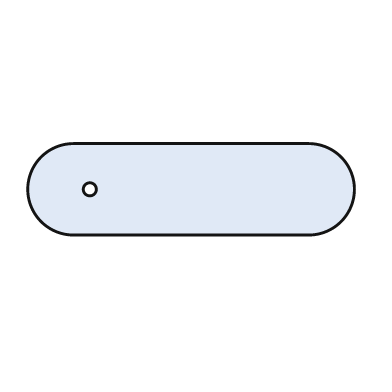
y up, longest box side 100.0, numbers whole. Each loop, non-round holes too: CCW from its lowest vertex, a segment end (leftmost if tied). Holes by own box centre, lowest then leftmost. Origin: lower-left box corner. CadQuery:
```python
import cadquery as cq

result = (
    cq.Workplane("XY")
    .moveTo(14.0, 0.0)
    .lineTo(86.0, 0.0)
    .threePointArc((100.0, 14.0), (86.0, 28.0))
    .lineTo(14.0, 28.0)
    .threePointArc((0.0, 14.0), (14.0, 0.0))
    .close()
    .moveTo(19.0, 14.0)
    .circle(2.0)
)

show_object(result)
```